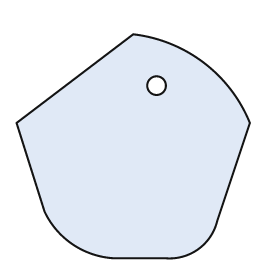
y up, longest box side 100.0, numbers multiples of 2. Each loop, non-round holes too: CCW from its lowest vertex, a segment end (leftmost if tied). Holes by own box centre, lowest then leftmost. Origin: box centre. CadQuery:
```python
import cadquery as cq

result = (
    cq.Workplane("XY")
    .moveTo(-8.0, -48.0)
    .lineTo(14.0, -48.0)
    .threePointArc((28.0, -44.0), (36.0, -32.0))
    .lineTo(50.0, 10.0)
    .threePointArc((30.0, 36.0), (0.0, 48.0))
    .lineTo(-50.0, 10.0)
    .lineTo(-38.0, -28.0)
    .threePointArc((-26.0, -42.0), (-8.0, -48.0))
    .close()
    .moveTo(10.0, 26.0)
    .circle(4.0)
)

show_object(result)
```